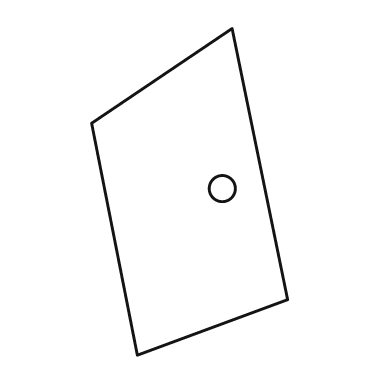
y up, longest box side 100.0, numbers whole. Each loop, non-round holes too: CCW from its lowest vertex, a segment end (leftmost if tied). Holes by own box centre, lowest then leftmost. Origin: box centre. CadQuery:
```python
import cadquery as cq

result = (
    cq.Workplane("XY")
    .moveTo(-16.0, -50.0)
    .lineTo(30.0, -33.0)
    .lineTo(13.0, 50.0)
    .lineTo(-30.0, 21.0)
    .close()
    .moveTo(10.0, 1.0)
    .circle(4.0)
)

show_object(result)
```